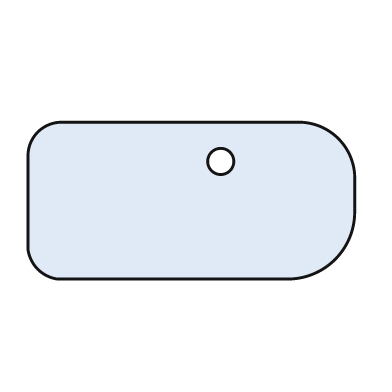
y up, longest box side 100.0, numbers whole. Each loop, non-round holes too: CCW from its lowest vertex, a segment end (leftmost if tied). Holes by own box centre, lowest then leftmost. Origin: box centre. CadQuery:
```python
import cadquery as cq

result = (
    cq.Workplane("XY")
    .moveTo(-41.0, -24.0)
    .lineTo(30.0, -24.0)
    .threePointArc((44.0, -18.0), (50.0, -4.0))
    .lineTo(50.0, 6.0)
    .threePointArc((45.0, 19.0), (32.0, 24.0))
    .lineTo(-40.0, 24.0)
    .threePointArc((-47.0, 21.0), (-50.0, 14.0))
    .lineTo(-50.0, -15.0)
    .threePointArc((-47.0, -21.0), (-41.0, -24.0))
    .close()
    .moveTo(9.0, 12.0)
    .circle(4.0)
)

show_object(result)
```